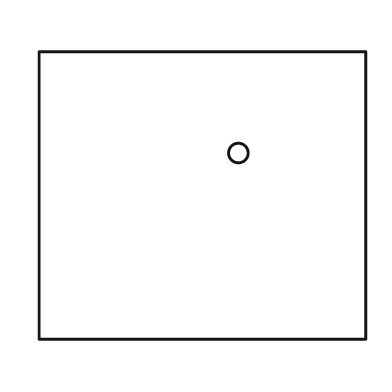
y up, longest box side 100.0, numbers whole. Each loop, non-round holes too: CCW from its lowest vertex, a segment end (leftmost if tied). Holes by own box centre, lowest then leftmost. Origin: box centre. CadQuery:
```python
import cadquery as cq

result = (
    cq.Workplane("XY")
    .moveTo(-50.0, -44.0)
    .lineTo(50.0, -44.0)
    .lineTo(50.0, 44.0)
    .lineTo(-50.0, 44.0)
    .close()
    .moveTo(11.0, 13.0)
    .circle(3.0)
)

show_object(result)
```